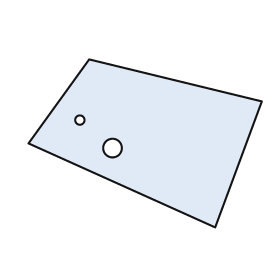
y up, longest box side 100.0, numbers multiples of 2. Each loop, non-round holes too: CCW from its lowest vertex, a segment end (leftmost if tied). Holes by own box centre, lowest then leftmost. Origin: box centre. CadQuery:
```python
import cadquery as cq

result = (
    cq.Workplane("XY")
    .moveTo(30.0, -36.0)
    .lineTo(50.0, 18.0)
    .lineTo(-24.0, 36.0)
    .lineTo(-50.0, 0.0)
    .close()
    .moveTo(-14.0, -2.0)
    .circle(4.0)
    .moveTo(-28.0, 10.0)
    .circle(2.0)
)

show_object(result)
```